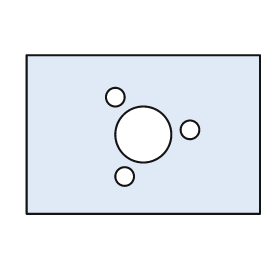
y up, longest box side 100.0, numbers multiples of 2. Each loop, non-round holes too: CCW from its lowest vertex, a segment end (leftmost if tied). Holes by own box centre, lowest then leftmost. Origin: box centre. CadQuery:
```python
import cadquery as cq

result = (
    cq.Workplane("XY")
    .moveTo(-50.0, -34.0)
    .lineTo(50.0, -34.0)
    .lineTo(50.0, 34.0)
    .lineTo(-50.0, 34.0)
    .close()
    .moveTo(-8.0, -18.0)
    .circle(4.0)
    .moveTo(0.0, 0.0)
    .circle(12.0)
    .moveTo(20.0, 2.0)
    .circle(4.0)
    .moveTo(-12.0, 16.0)
    .circle(4.0)
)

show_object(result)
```